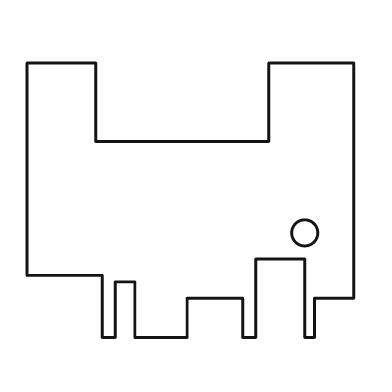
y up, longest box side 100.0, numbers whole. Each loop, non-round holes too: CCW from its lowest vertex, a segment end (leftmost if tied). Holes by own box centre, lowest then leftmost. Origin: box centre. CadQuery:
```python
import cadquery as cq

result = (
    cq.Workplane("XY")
    .moveTo(-27.0, -42.0)
    .lineTo(-23.0, -42.0)
    .lineTo(-23.0, -25.0)
    .lineTo(-17.0, -25.0)
    .lineTo(-17.0, -42.0)
    .lineTo(-1.0, -42.0)
    .lineTo(-1.0, -30.0)
    .lineTo(16.0, -30.0)
    .lineTo(16.0, -42.0)
    .lineTo(20.0, -42.0)
    .lineTo(20.0, -18.0)
    .lineTo(35.0, -18.0)
    .lineTo(35.0, -42.0)
    .lineTo(38.0, -42.0)
    .lineTo(38.0, -30.0)
    .lineTo(50.0, -30.0)
    .lineTo(50.0, 42.0)
    .lineTo(24.0, 42.0)
    .lineTo(24.0, 18.0)
    .lineTo(-29.0, 18.0)
    .lineTo(-29.0, 42.0)
    .lineTo(-50.0, 42.0)
    .lineTo(-50.0, -23.0)
    .lineTo(-27.0, -23.0)
    .close()
    .moveTo(35.0, -10.0)
    .circle(4.0)
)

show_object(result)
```